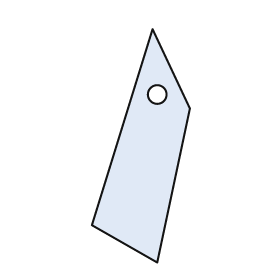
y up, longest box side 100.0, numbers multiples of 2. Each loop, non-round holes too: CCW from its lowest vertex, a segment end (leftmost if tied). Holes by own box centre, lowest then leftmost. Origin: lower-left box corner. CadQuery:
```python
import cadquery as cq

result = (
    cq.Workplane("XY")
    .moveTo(28.0, 0.0)
    .lineTo(42.0, 66.0)
    .lineTo(26.0, 100.0)
    .lineTo(0.0, 16.0)
    .close()
    .moveTo(28.0, 72.0)
    .circle(4.0)
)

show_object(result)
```